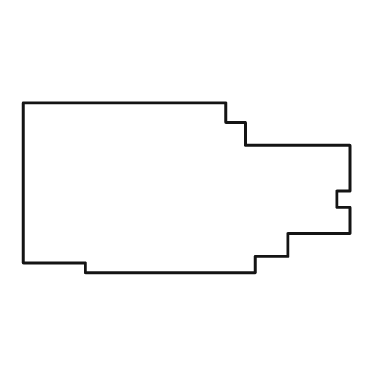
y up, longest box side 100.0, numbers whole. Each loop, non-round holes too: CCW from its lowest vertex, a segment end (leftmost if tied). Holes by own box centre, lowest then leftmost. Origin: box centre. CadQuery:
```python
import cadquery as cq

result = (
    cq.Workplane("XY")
    .moveTo(-31.0, -26.0)
    .lineTo(21.0, -26.0)
    .lineTo(21.0, -21.0)
    .lineTo(31.0, -21.0)
    .lineTo(31.0, -14.0)
    .lineTo(50.0, -14.0)
    .lineTo(50.0, -6.0)
    .lineTo(46.0, -6.0)
    .lineTo(46.0, -1.0)
    .lineTo(50.0, -1.0)
    .lineTo(50.0, 13.0)
    .lineTo(18.0, 13.0)
    .lineTo(18.0, 20.0)
    .lineTo(12.0, 20.0)
    .lineTo(12.0, 26.0)
    .lineTo(-50.0, 26.0)
    .lineTo(-50.0, -23.0)
    .lineTo(-31.0, -23.0)
    .close()
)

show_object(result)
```